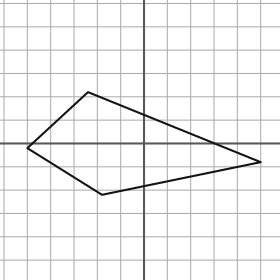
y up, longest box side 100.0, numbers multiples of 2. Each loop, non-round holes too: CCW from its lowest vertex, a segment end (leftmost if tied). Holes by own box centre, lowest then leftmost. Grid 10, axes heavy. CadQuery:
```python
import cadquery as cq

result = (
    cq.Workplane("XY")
    .moveTo(-18.0, -22.0)
    .lineTo(50.0, -8.0)
    .lineTo(-24.0, 22.0)
    .lineTo(-50.0, -2.0)
    .close()
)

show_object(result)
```